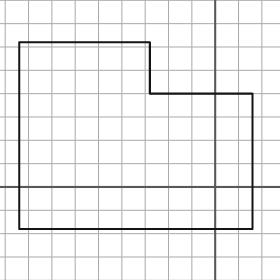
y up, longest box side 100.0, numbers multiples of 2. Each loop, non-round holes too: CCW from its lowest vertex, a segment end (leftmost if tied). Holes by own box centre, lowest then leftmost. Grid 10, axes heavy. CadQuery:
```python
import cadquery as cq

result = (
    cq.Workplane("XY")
    .moveTo(-84.0, -18.0)
    .lineTo(16.0, -18.0)
    .lineTo(16.0, 40.0)
    .lineTo(-28.0, 40.0)
    .lineTo(-28.0, 62.0)
    .lineTo(-84.0, 62.0)
    .close()
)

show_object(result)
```